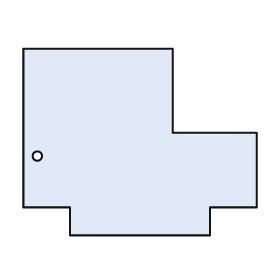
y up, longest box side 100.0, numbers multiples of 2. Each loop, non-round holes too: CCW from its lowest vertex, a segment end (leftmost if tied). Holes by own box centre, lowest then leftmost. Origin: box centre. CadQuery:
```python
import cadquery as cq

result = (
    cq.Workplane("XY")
    .moveTo(-30.0, -40.0)
    .lineTo(30.0, -40.0)
    .lineTo(30.0, -28.0)
    .lineTo(50.0, -28.0)
    .lineTo(50.0, 4.0)
    .lineTo(14.0, 4.0)
    .lineTo(14.0, 40.0)
    .lineTo(-50.0, 40.0)
    .lineTo(-50.0, -28.0)
    .lineTo(-30.0, -28.0)
    .close()
    .moveTo(-44.0, -6.0)
    .circle(2.0)
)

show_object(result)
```